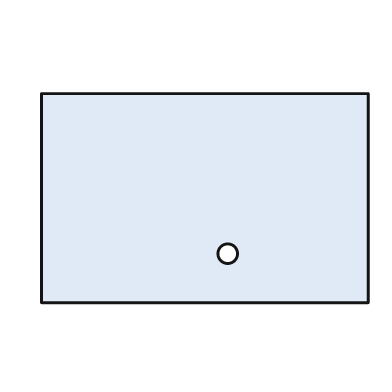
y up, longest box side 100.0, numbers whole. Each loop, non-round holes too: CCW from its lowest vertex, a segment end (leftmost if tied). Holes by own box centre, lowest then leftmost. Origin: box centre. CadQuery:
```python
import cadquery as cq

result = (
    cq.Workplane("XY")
    .moveTo(-50.0, -32.0)
    .lineTo(50.0, -32.0)
    .lineTo(50.0, 32.0)
    .lineTo(-50.0, 32.0)
    .close()
    .moveTo(7.0, -17.0)
    .circle(3.0)
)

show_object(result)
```